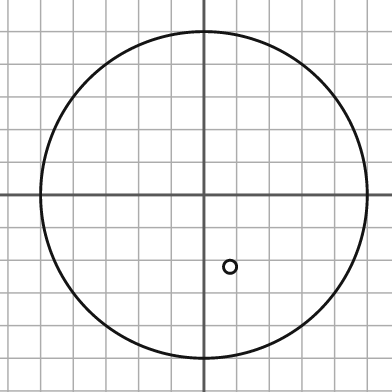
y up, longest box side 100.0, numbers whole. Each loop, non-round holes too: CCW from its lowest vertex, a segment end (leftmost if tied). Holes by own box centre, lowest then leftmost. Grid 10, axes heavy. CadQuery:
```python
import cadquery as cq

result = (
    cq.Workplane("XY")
    .moveTo(0.0, 0.0)
    .circle(50.0)
    .moveTo(8.0, -22.0)
    .circle(2.0)
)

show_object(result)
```